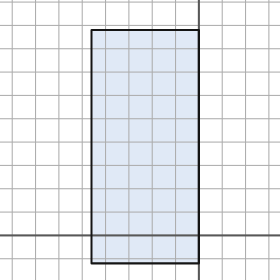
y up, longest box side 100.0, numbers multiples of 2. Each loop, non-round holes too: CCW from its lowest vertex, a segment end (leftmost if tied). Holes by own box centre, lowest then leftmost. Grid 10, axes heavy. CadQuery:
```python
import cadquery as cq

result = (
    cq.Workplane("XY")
    .moveTo(-46.0, -12.0)
    .lineTo(0.0, -12.0)
    .lineTo(0.0, 88.0)
    .lineTo(-46.0, 88.0)
    .close()
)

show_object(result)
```